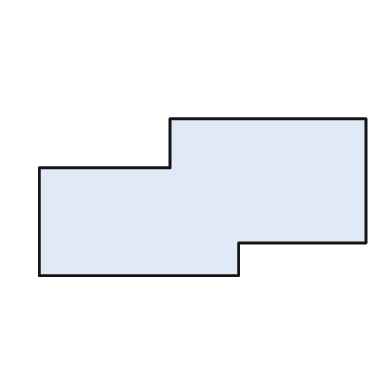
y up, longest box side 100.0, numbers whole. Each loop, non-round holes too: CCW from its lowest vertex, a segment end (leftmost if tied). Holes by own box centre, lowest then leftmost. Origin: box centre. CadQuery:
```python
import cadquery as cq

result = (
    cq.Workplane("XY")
    .moveTo(-50.0, -24.0)
    .lineTo(11.0, -24.0)
    .lineTo(11.0, -14.0)
    .lineTo(50.0, -14.0)
    .lineTo(50.0, 24.0)
    .lineTo(-10.0, 24.0)
    .lineTo(-10.0, 9.0)
    .lineTo(-50.0, 9.0)
    .close()
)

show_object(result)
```